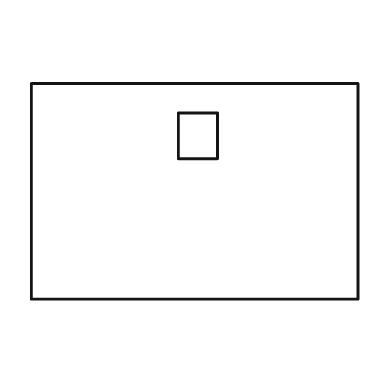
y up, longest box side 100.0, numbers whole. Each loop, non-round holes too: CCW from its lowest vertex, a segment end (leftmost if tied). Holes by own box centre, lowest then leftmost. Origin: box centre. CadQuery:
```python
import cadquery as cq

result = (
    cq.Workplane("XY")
    .moveTo(-50.0, -33.0)
    .lineTo(50.0, -33.0)
    .lineTo(50.0, 33.0)
    .lineTo(-50.0, 33.0)
    .close()
    .moveTo(-5.0, 10.0)
    .lineTo(7.0, 10.0)
    .lineTo(7.0, 24.0)
    .lineTo(-5.0, 24.0)
    .close()
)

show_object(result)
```